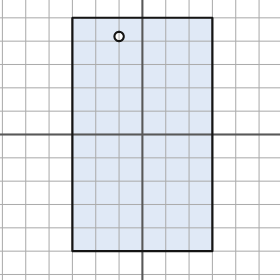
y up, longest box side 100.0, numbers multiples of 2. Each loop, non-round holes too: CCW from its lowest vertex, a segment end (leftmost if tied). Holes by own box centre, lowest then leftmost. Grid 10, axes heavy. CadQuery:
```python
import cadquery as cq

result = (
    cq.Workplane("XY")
    .moveTo(-30.0, -50.0)
    .lineTo(30.0, -50.0)
    .lineTo(30.0, 50.0)
    .lineTo(-30.0, 50.0)
    .close()
    .moveTo(-10.0, 42.0)
    .circle(2.0)
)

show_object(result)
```